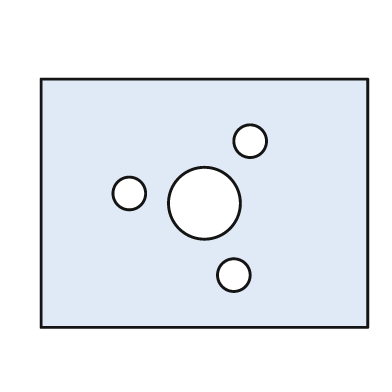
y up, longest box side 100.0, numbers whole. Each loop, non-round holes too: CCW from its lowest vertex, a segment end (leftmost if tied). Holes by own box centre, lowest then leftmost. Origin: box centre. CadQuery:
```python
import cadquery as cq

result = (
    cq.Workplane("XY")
    .moveTo(-50.0, -38.0)
    .lineTo(50.0, -38.0)
    .lineTo(50.0, 38.0)
    .lineTo(-50.0, 38.0)
    .close()
    .moveTo(9.0, -22.0)
    .circle(5.0)
    .moveTo(0.0, 0.0)
    .circle(11.0)
    .moveTo(-23.0, 3.0)
    .circle(5.0)
    .moveTo(14.0, 19.0)
    .circle(5.0)
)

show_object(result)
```